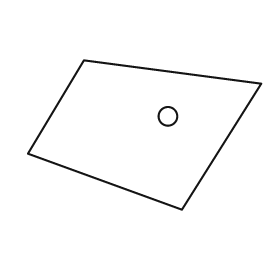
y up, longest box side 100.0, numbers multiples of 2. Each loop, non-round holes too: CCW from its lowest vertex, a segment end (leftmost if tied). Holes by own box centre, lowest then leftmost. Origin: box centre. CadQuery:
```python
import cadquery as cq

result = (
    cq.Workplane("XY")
    .moveTo(16.0, -32.0)
    .lineTo(50.0, 22.0)
    .lineTo(-26.0, 32.0)
    .lineTo(-50.0, -8.0)
    .close()
    .moveTo(10.0, 8.0)
    .circle(4.0)
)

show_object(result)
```